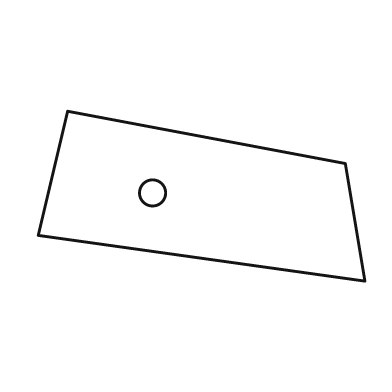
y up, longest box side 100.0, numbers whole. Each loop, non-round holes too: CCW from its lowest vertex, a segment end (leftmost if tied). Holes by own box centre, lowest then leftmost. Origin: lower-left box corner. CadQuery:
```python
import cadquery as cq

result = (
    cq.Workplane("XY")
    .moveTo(100.0, 0.0)
    .lineTo(94.0, 36.0)
    .lineTo(9.0, 52.0)
    .lineTo(0.0, 14.0)
    .close()
    .moveTo(35.0, 27.0)
    .circle(4.0)
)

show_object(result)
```